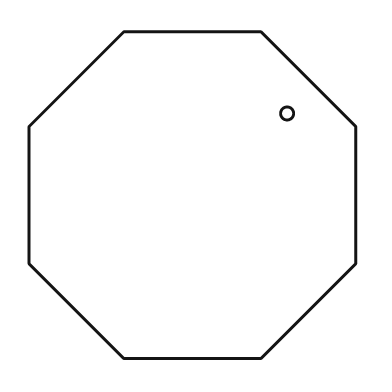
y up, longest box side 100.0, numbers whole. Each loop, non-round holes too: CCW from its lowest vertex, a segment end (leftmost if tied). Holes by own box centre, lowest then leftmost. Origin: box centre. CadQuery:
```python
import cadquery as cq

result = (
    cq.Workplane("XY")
    .moveTo(-21.0, -50.0)
    .lineTo(21.0, -50.0)
    .lineTo(50.0, -21.0)
    .lineTo(50.0, 21.0)
    .lineTo(21.0, 50.0)
    .lineTo(-21.0, 50.0)
    .lineTo(-50.0, 21.0)
    .lineTo(-50.0, -21.0)
    .close()
    .moveTo(29.0, 25.0)
    .circle(2.0)
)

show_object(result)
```